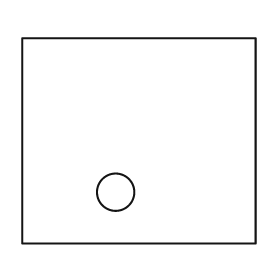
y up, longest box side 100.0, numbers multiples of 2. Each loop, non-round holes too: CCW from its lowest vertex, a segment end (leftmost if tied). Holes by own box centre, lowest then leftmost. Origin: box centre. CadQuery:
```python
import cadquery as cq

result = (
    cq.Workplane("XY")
    .moveTo(-50.0, -44.0)
    .lineTo(50.0, -44.0)
    .lineTo(50.0, 44.0)
    .lineTo(-50.0, 44.0)
    .close()
    .moveTo(-10.0, -22.0)
    .circle(8.0)
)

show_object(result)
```